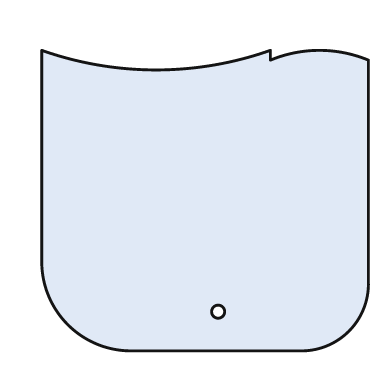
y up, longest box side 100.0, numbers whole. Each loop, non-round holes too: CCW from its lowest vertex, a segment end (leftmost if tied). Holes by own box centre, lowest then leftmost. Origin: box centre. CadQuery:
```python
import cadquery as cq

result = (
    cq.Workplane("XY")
    .moveTo(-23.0, -46.0)
    .lineTo(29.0, -46.0)
    .threePointArc((44.0, -40.0), (50.0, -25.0))
    .lineTo(50.0, 43.0)
    .threePointArc((35.0, 46.0), (20.0, 43.0))
    .lineTo(20.0, 46.0)
    .threePointArc((-15.0, 40.0), (-50.0, 46.0))
    .lineTo(-50.0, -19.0)
    .threePointArc((-42.0, -38.0), (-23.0, -46.0))
    .close()
    .moveTo(4.0, -34.0)
    .circle(2.0)
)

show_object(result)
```